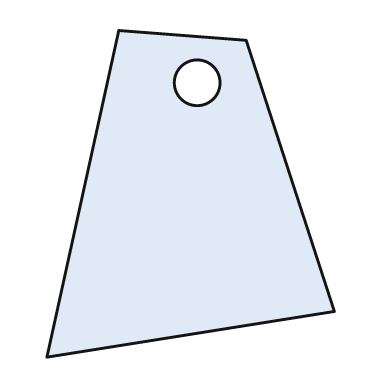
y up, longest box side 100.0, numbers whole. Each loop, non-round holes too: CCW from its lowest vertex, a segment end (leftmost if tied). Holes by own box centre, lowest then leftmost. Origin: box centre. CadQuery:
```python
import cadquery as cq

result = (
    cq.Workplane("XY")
    .moveTo(-44.0, -50.0)
    .lineTo(44.0, -36.0)
    .lineTo(17.0, 47.0)
    .lineTo(-22.0, 50.0)
    .close()
    .moveTo(2.0, 34.0)
    .circle(7.0)
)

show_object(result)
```